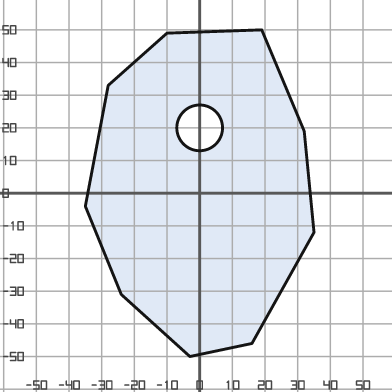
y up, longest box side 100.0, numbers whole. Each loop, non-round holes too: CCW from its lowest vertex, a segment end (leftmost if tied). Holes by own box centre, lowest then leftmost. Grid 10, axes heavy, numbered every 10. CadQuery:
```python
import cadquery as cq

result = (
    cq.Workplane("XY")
    .moveTo(-3.0, -50.0)
    .lineTo(16.0, -46.0)
    .lineTo(35.0, -12.0)
    .lineTo(32.0, 19.0)
    .lineTo(19.0, 50.0)
    .lineTo(-10.0, 49.0)
    .lineTo(-28.0, 33.0)
    .lineTo(-35.0, -4.0)
    .lineTo(-24.0, -31.0)
    .close()
    .moveTo(0.0, 20.0)
    .circle(7.0)
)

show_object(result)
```